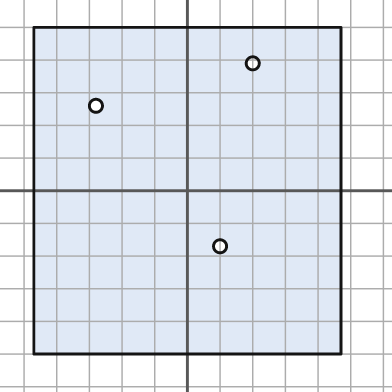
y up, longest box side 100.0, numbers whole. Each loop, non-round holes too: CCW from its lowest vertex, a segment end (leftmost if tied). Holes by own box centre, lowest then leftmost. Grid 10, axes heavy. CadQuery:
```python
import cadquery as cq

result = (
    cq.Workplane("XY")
    .moveTo(-47.0, -50.0)
    .lineTo(47.0, -50.0)
    .lineTo(47.0, 50.0)
    .lineTo(-47.0, 50.0)
    .close()
    .moveTo(10.0, -17.0)
    .circle(2.0)
    .moveTo(-28.0, 26.0)
    .circle(2.0)
    .moveTo(20.0, 39.0)
    .circle(2.0)
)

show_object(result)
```